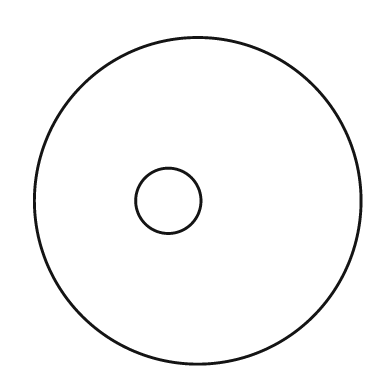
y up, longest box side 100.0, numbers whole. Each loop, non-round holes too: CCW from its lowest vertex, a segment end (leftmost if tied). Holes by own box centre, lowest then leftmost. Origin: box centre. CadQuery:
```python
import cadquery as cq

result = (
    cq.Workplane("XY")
    .moveTo(0.0, 0.0)
    .circle(50.0)
    .moveTo(-9.0, 0.0)
    .circle(10.0)
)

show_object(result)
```